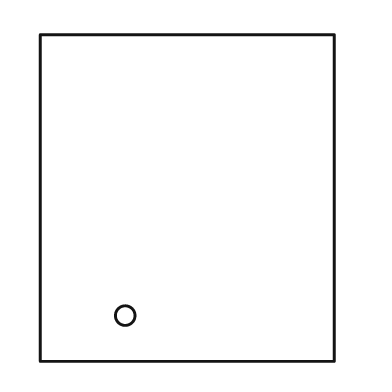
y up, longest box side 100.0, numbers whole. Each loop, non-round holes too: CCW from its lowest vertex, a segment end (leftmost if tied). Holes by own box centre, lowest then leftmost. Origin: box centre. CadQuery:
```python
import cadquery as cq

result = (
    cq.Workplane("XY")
    .moveTo(-45.0, -50.0)
    .lineTo(45.0, -50.0)
    .lineTo(45.0, 50.0)
    .lineTo(-45.0, 50.0)
    .close()
    .moveTo(-19.0, -36.0)
    .circle(3.0)
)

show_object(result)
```